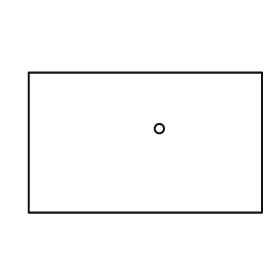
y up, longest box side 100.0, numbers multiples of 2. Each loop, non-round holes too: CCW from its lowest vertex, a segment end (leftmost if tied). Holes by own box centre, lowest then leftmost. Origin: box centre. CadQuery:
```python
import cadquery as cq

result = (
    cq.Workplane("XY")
    .moveTo(-50.0, -30.0)
    .lineTo(50.0, -30.0)
    .lineTo(50.0, 30.0)
    .lineTo(-50.0, 30.0)
    .close()
    .moveTo(6.0, 6.0)
    .circle(2.0)
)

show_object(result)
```